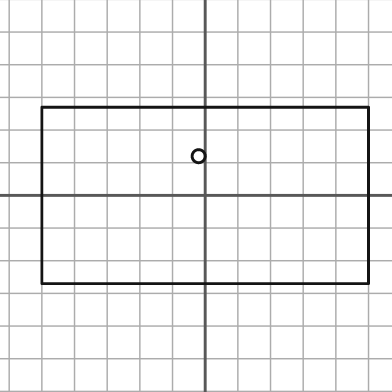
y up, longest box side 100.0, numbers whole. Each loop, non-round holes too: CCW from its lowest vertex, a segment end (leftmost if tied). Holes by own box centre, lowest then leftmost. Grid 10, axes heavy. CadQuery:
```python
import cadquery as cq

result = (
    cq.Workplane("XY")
    .moveTo(-50.0, -27.0)
    .lineTo(50.0, -27.0)
    .lineTo(50.0, 27.0)
    .lineTo(-50.0, 27.0)
    .close()
    .moveTo(-2.0, 12.0)
    .circle(2.0)
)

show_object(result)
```